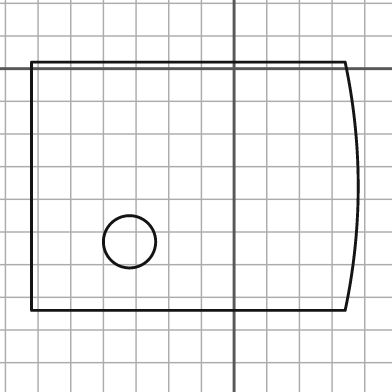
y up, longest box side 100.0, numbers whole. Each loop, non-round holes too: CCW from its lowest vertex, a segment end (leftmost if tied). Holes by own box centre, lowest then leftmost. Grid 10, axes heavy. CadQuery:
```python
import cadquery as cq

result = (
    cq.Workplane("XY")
    .moveTo(-62.0, -74.0)
    .lineTo(34.0, -74.0)
    .threePointArc((38.0, -36.0), (34.0, 2.0))
    .lineTo(-62.0, 2.0)
    .close()
    .moveTo(-32.0, -53.0)
    .circle(8.0)
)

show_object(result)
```